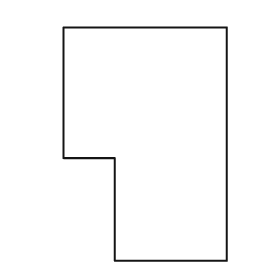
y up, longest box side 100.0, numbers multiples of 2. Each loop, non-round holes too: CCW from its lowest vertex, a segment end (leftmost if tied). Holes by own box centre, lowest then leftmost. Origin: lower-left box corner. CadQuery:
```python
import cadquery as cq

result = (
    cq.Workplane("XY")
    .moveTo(22.0, 0.0)
    .lineTo(70.0, 0.0)
    .lineTo(70.0, 100.0)
    .lineTo(0.0, 100.0)
    .lineTo(0.0, 44.0)
    .lineTo(22.0, 44.0)
    .close()
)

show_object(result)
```